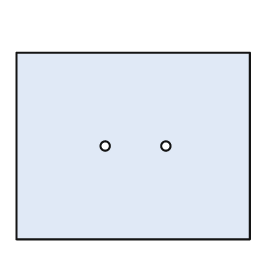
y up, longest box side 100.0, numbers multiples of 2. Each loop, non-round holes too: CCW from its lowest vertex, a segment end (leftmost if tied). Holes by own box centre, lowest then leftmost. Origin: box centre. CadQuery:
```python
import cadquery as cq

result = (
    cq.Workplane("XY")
    .moveTo(-50.0, -40.0)
    .lineTo(50.0, -40.0)
    .lineTo(50.0, 40.0)
    .lineTo(-50.0, 40.0)
    .close()
    .moveTo(-12.0, 0.0)
    .circle(2.0)
    .moveTo(14.0, 0.0)
    .circle(2.0)
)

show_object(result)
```